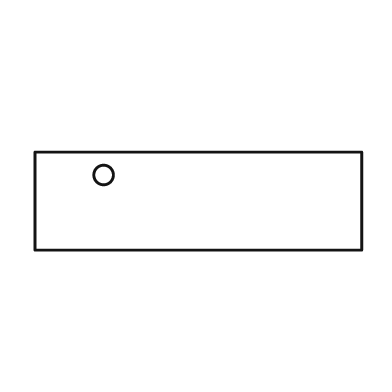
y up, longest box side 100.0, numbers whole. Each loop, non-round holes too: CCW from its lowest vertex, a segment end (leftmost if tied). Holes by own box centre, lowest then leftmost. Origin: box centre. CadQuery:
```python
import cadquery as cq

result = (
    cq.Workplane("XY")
    .moveTo(-50.0, -15.0)
    .lineTo(50.0, -15.0)
    .lineTo(50.0, 15.0)
    .lineTo(-50.0, 15.0)
    .close()
    .moveTo(-29.0, 8.0)
    .circle(3.0)
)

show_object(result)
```